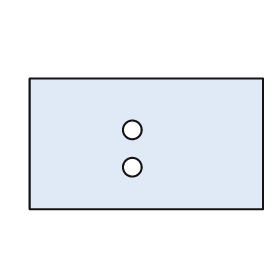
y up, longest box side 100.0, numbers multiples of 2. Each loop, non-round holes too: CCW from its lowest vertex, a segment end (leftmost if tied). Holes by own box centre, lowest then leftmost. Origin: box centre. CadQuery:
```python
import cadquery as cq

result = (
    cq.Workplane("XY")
    .moveTo(-50.0, -28.0)
    .lineTo(50.0, -28.0)
    .lineTo(50.0, 28.0)
    .lineTo(-50.0, 28.0)
    .close()
    .moveTo(-6.0, -10.0)
    .circle(4.0)
    .moveTo(-6.0, 6.0)
    .circle(4.0)
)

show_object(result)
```